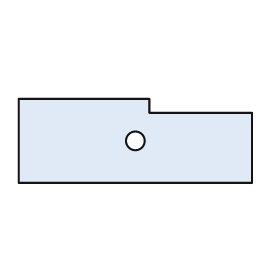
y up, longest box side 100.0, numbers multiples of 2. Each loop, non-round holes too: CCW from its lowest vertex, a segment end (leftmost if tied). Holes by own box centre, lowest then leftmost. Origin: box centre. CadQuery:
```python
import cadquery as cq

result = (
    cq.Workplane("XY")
    .moveTo(-50.0, -18.0)
    .lineTo(50.0, -18.0)
    .lineTo(50.0, 12.0)
    .lineTo(6.0, 12.0)
    .lineTo(6.0, 18.0)
    .lineTo(-50.0, 18.0)
    .close()
    .moveTo(0.0, 0.0)
    .circle(4.0)
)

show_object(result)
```